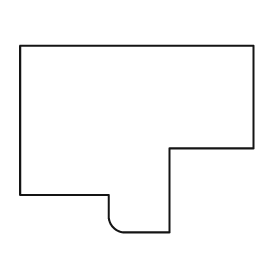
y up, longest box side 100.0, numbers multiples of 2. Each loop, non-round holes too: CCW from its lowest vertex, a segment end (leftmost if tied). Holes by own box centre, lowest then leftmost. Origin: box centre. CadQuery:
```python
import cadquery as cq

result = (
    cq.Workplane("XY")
    .moveTo(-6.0, -40.0)
    .lineTo(14.0, -40.0)
    .lineTo(14.0, -4.0)
    .lineTo(50.0, -4.0)
    .lineTo(50.0, 40.0)
    .lineTo(-50.0, 40.0)
    .lineTo(-50.0, -24.0)
    .lineTo(-12.0, -24.0)
    .lineTo(-12.0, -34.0)
    .threePointArc((-10.0, -38.0), (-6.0, -40.0))
    .close()
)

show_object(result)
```